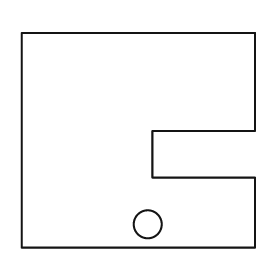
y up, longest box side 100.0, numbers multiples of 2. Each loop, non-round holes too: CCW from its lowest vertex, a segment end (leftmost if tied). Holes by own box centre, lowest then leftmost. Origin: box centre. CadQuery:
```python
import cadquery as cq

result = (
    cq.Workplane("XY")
    .moveTo(-50.0, -46.0)
    .lineTo(50.0, -46.0)
    .lineTo(50.0, -16.0)
    .lineTo(6.0, -16.0)
    .lineTo(6.0, 4.0)
    .lineTo(50.0, 4.0)
    .lineTo(50.0, 46.0)
    .lineTo(-50.0, 46.0)
    .close()
    .moveTo(4.0, -36.0)
    .circle(6.0)
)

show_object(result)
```